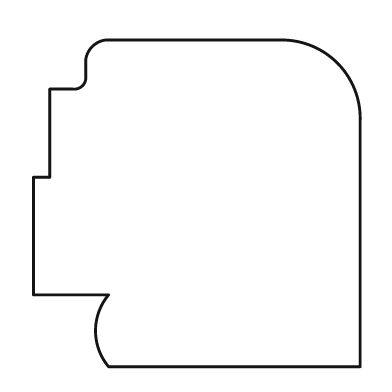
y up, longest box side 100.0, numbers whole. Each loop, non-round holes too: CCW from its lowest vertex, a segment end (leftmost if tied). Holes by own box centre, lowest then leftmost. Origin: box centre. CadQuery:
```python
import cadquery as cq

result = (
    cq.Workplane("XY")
    .moveTo(-27.0, -50.0)
    .lineTo(50.0, -50.0)
    .lineTo(50.0, 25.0)
    .threePointArc((43.0, 43.0), (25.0, 50.0))
    .lineTo(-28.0, 50.0)
    .threePointArc((-32.0, 48.0), (-34.0, 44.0))
    .lineTo(-34.0, 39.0)
    .threePointArc((-35.0, 36.0), (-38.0, 35.0))
    .lineTo(-45.0, 35.0)
    .lineTo(-45.0, 8.0)
    .lineTo(-50.0, 8.0)
    .lineTo(-50.0, -28.0)
    .lineTo(-27.0, -28.0)
    .threePointArc((-31.0, -39.0), (-27.0, -50.0))
    .close()
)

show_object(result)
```